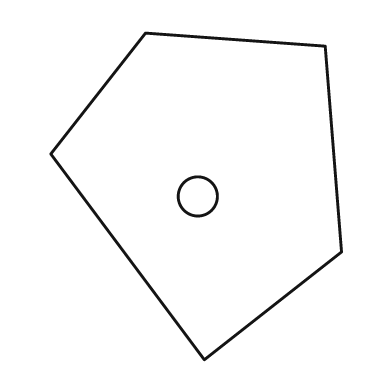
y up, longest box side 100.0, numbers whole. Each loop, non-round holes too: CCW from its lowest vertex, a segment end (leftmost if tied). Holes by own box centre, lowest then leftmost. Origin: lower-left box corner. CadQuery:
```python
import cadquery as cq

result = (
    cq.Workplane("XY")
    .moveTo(47.0, 0.0)
    .lineTo(89.0, 33.0)
    .lineTo(84.0, 96.0)
    .lineTo(29.0, 100.0)
    .lineTo(0.0, 63.0)
    .close()
    .moveTo(45.0, 50.0)
    .circle(6.0)
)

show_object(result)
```